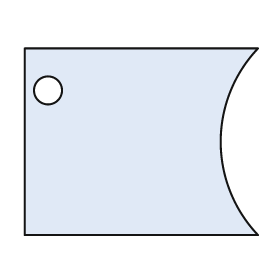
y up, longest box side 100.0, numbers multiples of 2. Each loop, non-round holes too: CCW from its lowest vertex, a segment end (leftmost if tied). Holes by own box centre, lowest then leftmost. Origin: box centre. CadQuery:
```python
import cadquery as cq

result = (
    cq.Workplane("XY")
    .moveTo(-50.0, -40.0)
    .lineTo(50.0, -40.0)
    .threePointArc((34.0, 0.0), (50.0, 40.0))
    .lineTo(-50.0, 40.0)
    .close()
    .moveTo(-40.0, 22.0)
    .circle(6.0)
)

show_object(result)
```